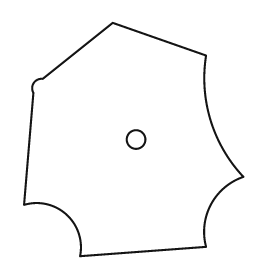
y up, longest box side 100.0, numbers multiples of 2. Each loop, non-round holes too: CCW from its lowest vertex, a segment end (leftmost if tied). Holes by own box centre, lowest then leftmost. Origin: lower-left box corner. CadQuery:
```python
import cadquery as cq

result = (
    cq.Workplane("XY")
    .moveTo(24.0, 0.0)
    .lineTo(78.0, 4.0)
    .threePointArc((80.0, 22.0), (94.0, 34.0))
    .threePointArc((80.0, 58.0), (78.0, 86.0))
    .lineTo(38.0, 100.0)
    .lineTo(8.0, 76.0)
    .threePointArc((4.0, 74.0), (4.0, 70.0))
    .lineTo(0.0, 22.0)
    .threePointArc((18.0, 18.0), (24.0, 0.0))
    .close()
    .moveTo(48.0, 50.0)
    .circle(4.0)
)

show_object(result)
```